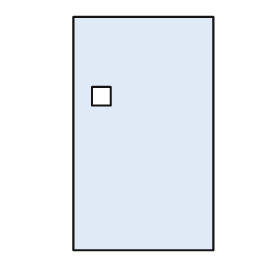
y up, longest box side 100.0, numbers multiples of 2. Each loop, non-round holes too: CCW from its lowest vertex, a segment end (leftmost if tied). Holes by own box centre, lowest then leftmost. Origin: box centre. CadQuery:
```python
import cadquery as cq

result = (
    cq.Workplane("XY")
    .moveTo(-30.0, -50.0)
    .lineTo(30.0, -50.0)
    .lineTo(30.0, 50.0)
    .lineTo(-30.0, 50.0)
    .close()
    .moveTo(-22.0, 12.0)
    .lineTo(-14.0, 12.0)
    .lineTo(-14.0, 20.0)
    .lineTo(-22.0, 20.0)
    .close()
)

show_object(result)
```